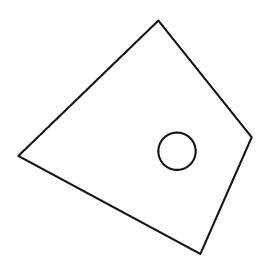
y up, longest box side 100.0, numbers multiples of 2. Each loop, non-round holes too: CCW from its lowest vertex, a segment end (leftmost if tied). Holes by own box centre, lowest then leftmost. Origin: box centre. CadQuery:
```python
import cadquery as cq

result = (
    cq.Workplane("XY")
    .moveTo(28.0, -50.0)
    .lineTo(50.0, 0.0)
    .lineTo(10.0, 50.0)
    .lineTo(-50.0, -8.0)
    .close()
    .moveTo(18.0, -6.0)
    .circle(8.0)
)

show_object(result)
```